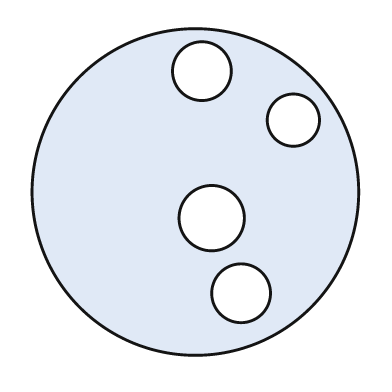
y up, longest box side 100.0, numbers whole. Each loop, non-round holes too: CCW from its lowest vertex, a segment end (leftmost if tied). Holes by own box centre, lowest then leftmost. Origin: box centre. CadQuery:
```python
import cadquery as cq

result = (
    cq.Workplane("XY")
    .moveTo(0.0, 0.0)
    .circle(50.0)
    .moveTo(14.0, -31.0)
    .circle(9.0)
    .moveTo(5.0, -8.0)
    .circle(10.0)
    .moveTo(30.0, 22.0)
    .circle(8.0)
    .moveTo(2.0, 37.0)
    .circle(9.0)
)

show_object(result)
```